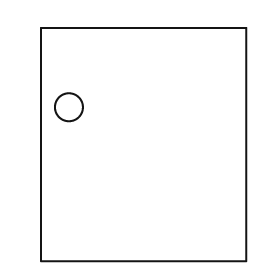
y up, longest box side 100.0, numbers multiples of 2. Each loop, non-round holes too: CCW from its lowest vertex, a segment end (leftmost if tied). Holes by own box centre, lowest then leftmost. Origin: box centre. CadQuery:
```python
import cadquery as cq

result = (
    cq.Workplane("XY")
    .moveTo(-44.0, -50.0)
    .lineTo(44.0, -50.0)
    .lineTo(44.0, 50.0)
    .lineTo(-44.0, 50.0)
    .close()
    .moveTo(-32.0, 16.0)
    .circle(6.0)
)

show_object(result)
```